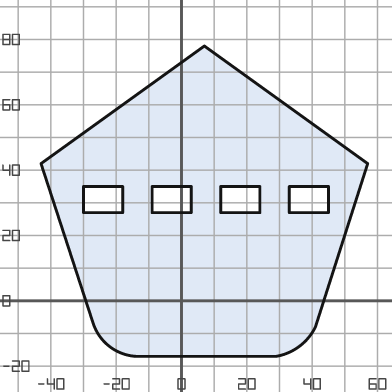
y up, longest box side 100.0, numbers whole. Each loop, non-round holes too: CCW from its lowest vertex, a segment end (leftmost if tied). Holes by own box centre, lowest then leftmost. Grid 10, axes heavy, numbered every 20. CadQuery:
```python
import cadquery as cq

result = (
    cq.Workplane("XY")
    .moveTo(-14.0, -17.0)
    .lineTo(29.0, -17.0)
    .threePointArc((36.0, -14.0), (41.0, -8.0))
    .lineTo(57.0, 42.0)
    .lineTo(7.0, 78.0)
    .lineTo(-43.0, 42.0)
    .lineTo(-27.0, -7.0)
    .threePointArc((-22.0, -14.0), (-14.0, -17.0))
    .close()
    .moveTo(-30.0, 27.0)
    .lineTo(-18.0, 27.0)
    .lineTo(-18.0, 35.0)
    .lineTo(-30.0, 35.0)
    .close()
    .moveTo(-9.0, 27.0)
    .lineTo(3.0, 27.0)
    .lineTo(3.0, 35.0)
    .lineTo(-9.0, 35.0)
    .close()
    .moveTo(12.0, 27.0)
    .lineTo(24.0, 27.0)
    .lineTo(24.0, 35.0)
    .lineTo(12.0, 35.0)
    .close()
    .moveTo(33.0, 27.0)
    .lineTo(45.0, 27.0)
    .lineTo(45.0, 35.0)
    .lineTo(33.0, 35.0)
    .close()
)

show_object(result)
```